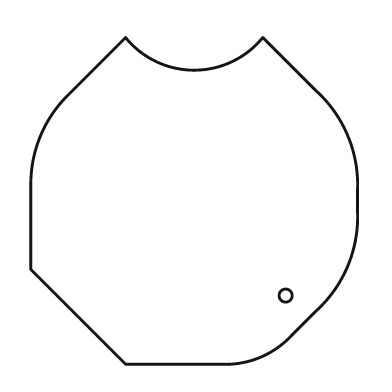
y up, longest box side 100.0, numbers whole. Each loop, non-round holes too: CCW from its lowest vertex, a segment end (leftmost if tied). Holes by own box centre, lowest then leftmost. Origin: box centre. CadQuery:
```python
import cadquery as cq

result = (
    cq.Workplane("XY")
    .moveTo(-21.0, -50.0)
    .lineTo(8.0, -50.0)
    .threePointArc((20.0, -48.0), (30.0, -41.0))
    .lineTo(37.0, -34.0)
    .threePointArc((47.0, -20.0), (50.0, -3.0))
    .lineTo(50.0, 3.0)
    .threePointArc((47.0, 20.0), (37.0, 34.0))
    .lineTo(21.0, 50.0)
    .threePointArc((0.0, 40.0), (-21.0, 50.0))
    .lineTo(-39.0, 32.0)
    .threePointArc((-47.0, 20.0), (-50.0, 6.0))
    .lineTo(-50.0, -21.0)
    .close()
    .moveTo(28.0, -29.0)
    .circle(2.0)
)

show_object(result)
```